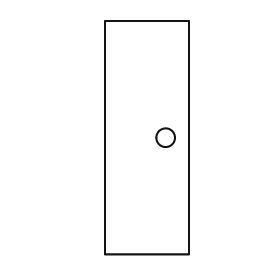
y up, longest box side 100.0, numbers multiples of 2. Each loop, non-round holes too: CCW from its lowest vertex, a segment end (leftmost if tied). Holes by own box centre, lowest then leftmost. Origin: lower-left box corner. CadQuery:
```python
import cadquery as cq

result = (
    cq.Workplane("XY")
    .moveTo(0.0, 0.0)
    .lineTo(36.0, 0.0)
    .lineTo(36.0, 100.0)
    .lineTo(0.0, 100.0)
    .close()
    .moveTo(26.0, 50.0)
    .circle(4.0)
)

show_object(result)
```